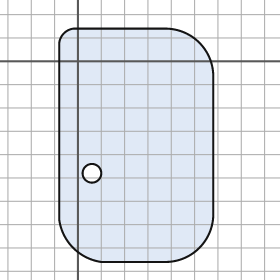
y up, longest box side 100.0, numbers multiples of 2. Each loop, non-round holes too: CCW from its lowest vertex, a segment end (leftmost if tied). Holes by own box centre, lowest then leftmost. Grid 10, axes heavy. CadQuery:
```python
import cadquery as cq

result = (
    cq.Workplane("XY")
    .moveTo(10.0, -86.0)
    .lineTo(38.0, -86.0)
    .threePointArc((52.0, -80.0), (58.0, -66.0))
    .lineTo(58.0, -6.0)
    .threePointArc((52.0, 8.0), (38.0, 14.0))
    .lineTo(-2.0, 14.0)
    .threePointArc((-6.0, 12.0), (-8.0, 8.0))
    .lineTo(-8.0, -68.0)
    .threePointArc((-2.0, -80.0), (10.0, -86.0))
    .close()
    .moveTo(6.0, -48.0)
    .circle(4.0)
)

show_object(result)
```